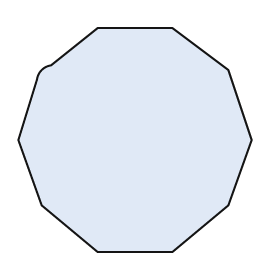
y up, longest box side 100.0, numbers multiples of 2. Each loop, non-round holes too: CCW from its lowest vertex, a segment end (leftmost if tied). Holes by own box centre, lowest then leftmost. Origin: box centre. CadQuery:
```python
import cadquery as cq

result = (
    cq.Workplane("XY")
    .moveTo(-16.0, -48.0)
    .lineTo(16.0, -48.0)
    .lineTo(40.0, -28.0)
    .lineTo(50.0, 0.0)
    .lineTo(40.0, 30.0)
    .lineTo(16.0, 48.0)
    .lineTo(-16.0, 48.0)
    .lineTo(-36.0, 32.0)
    .threePointArc((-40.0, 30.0), (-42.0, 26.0))
    .lineTo(-50.0, 0.0)
    .lineTo(-40.0, -28.0)
    .close()
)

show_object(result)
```